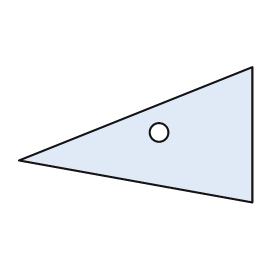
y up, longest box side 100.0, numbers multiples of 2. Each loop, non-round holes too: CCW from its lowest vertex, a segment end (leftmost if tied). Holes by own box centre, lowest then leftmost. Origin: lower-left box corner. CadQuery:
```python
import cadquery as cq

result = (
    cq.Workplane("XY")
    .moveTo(100.0, 0.0)
    .lineTo(100.0, 58.0)
    .lineTo(0.0, 18.0)
    .close()
    .moveTo(60.0, 30.0)
    .circle(4.0)
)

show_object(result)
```